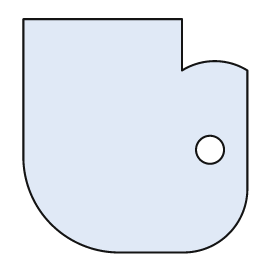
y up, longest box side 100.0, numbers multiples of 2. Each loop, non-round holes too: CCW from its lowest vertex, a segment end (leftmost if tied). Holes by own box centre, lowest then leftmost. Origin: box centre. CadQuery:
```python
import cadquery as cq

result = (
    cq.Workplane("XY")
    .moveTo(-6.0, -50.0)
    .lineTo(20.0, -50.0)
    .threePointArc((40.0, -42.0), (48.0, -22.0))
    .lineTo(48.0, 28.0)
    .threePointArc((34.0, 32.0), (20.0, 28.0))
    .lineTo(20.0, 50.0)
    .lineTo(-48.0, 50.0)
    .lineTo(-48.0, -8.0)
    .threePointArc((-36.0, -38.0), (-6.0, -50.0))
    .close()
    .moveTo(32.0, -6.0)
    .circle(6.0)
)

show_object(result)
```